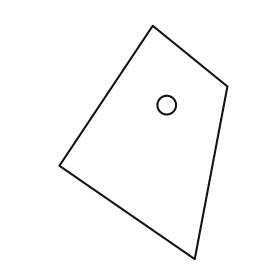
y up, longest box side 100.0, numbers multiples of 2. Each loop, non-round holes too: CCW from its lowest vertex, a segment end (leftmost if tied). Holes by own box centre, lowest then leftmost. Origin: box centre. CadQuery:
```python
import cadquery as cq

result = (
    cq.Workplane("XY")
    .moveTo(22.0, -50.0)
    .lineTo(36.0, 24.0)
    .lineTo(4.0, 50.0)
    .lineTo(-36.0, -10.0)
    .close()
    .moveTo(10.0, 16.0)
    .circle(4.0)
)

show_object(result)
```